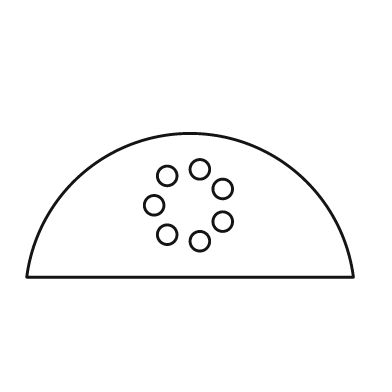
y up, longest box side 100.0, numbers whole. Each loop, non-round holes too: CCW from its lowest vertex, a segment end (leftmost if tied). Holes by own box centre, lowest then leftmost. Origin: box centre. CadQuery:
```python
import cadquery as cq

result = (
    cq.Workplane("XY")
    .moveTo(-50.0, -22.0)
    .lineTo(50.0, -22.0)
    .threePointArc((0.0, 22.0), (-50.0, -22.0))
    .close()
    .moveTo(3.0, -11.0)
    .circle(3.0)
    .moveTo(-7.0, -9.0)
    .circle(3.0)
    .moveTo(10.0, -5.0)
    .circle(3.0)
    .moveTo(-11.0, 0.0)
    .circle(3.0)
    .moveTo(10.0, 5.0)
    .circle(3.0)
    .moveTo(-7.0, 9.0)
    .circle(3.0)
    .moveTo(3.0, 11.0)
    .circle(3.0)
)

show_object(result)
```